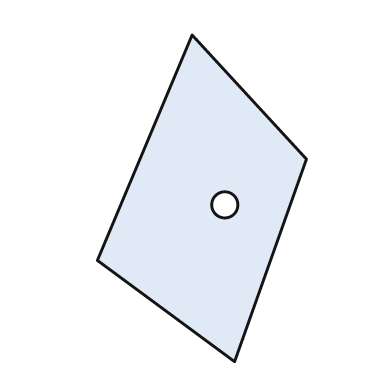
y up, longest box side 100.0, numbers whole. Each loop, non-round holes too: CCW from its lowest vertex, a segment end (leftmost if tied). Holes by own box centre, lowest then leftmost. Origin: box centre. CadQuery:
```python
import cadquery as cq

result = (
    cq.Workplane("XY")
    .moveTo(10.0, -50.0)
    .lineTo(32.0, 12.0)
    .lineTo(-3.0, 50.0)
    .lineTo(-32.0, -19.0)
    .close()
    .moveTo(7.0, -2.0)
    .circle(4.0)
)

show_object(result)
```